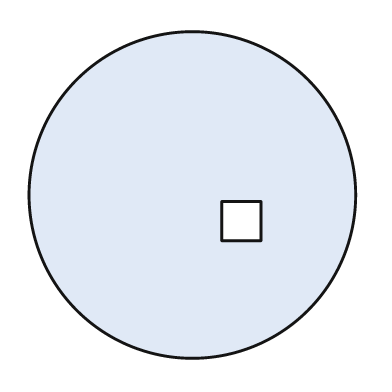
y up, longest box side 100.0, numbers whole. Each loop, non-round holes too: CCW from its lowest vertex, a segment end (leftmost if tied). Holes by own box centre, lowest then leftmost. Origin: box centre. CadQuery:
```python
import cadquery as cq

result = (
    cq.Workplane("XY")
    .moveTo(0.0, 0.0)
    .circle(50.0)
    .moveTo(9.0, -14.0)
    .lineTo(21.0, -14.0)
    .lineTo(21.0, -2.0)
    .lineTo(9.0, -2.0)
    .close()
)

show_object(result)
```